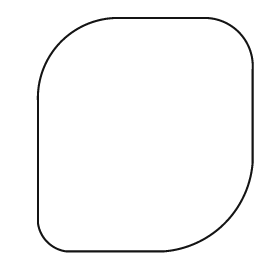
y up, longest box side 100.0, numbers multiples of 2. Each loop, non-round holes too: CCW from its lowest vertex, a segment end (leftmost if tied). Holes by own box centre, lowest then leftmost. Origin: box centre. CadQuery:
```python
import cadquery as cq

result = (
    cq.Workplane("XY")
    .moveTo(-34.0, -50.0)
    .lineTo(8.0, -50.0)
    .threePointArc((34.0, -38.0), (46.0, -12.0))
    .lineTo(46.0, 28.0)
    .threePointArc((40.0, 44.0), (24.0, 50.0))
    .lineTo(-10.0, 50.0)
    .threePointArc((-36.0, 40.0), (-46.0, 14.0))
    .lineTo(-46.0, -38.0)
    .threePointArc((-42.0, -46.0), (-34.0, -50.0))
    .close()
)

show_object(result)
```